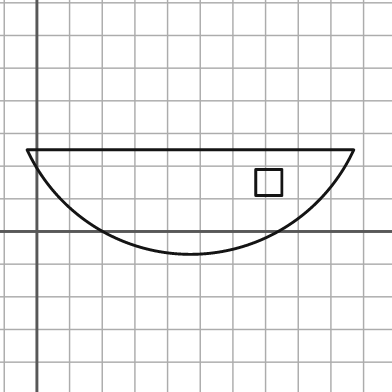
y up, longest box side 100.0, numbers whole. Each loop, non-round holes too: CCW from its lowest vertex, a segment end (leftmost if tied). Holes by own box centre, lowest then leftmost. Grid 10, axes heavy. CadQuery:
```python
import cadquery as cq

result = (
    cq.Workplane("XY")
    .moveTo(-3.0, 25.0)
    .threePointArc((47.0, -7.0), (97.0, 25.0))
    .close()
    .moveTo(67.0, 11.0)
    .lineTo(75.0, 11.0)
    .lineTo(75.0, 19.0)
    .lineTo(67.0, 19.0)
    .close()
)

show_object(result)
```